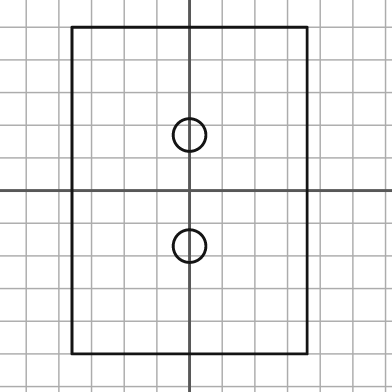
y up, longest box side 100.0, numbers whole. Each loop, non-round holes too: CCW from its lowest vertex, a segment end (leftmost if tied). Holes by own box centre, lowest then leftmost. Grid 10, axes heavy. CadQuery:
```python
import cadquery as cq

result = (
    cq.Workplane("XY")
    .moveTo(-36.0, -50.0)
    .lineTo(36.0, -50.0)
    .lineTo(36.0, 50.0)
    .lineTo(-36.0, 50.0)
    .close()
    .moveTo(0.0, -17.0)
    .circle(5.0)
    .moveTo(0.0, 17.0)
    .circle(5.0)
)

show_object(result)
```